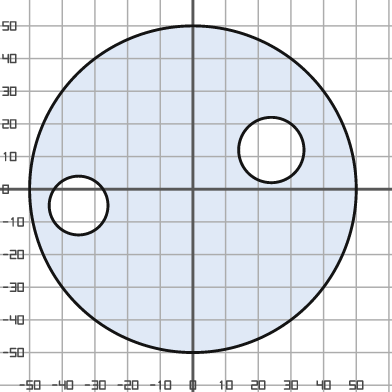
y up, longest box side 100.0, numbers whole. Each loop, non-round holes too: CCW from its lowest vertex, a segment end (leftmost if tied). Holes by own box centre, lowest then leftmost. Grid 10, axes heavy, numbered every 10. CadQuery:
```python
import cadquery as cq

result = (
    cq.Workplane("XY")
    .moveTo(0.0, 0.0)
    .circle(50.0)
    .moveTo(-35.0, -5.0)
    .circle(9.0)
    .moveTo(24.0, 12.0)
    .circle(10.0)
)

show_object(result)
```